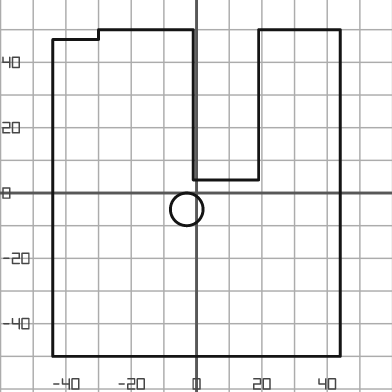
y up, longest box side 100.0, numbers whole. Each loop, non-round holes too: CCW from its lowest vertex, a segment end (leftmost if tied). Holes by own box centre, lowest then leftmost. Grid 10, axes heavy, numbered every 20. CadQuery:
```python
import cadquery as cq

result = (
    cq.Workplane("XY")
    .moveTo(-44.0, -50.0)
    .lineTo(44.0, -50.0)
    .lineTo(44.0, 50.0)
    .lineTo(19.0, 50.0)
    .lineTo(19.0, 4.0)
    .lineTo(-1.0, 4.0)
    .lineTo(-1.0, 50.0)
    .lineTo(-30.0, 50.0)
    .lineTo(-30.0, 47.0)
    .lineTo(-44.0, 47.0)
    .close()
    .moveTo(-3.0, -5.0)
    .circle(5.0)
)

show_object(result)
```